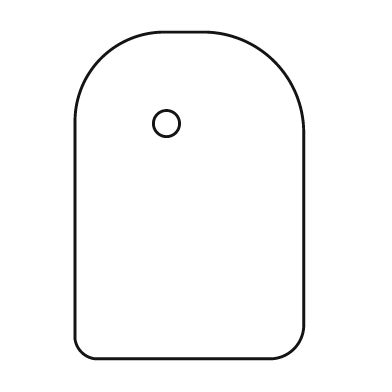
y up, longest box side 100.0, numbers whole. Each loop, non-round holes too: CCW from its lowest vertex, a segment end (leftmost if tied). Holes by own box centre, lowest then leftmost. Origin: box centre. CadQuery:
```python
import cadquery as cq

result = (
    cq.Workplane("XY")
    .moveTo(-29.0, -50.0)
    .lineTo(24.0, -50.0)
    .threePointArc((32.0, -47.0), (35.0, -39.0))
    .lineTo(35.0, 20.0)
    .threePointArc((26.0, 41.0), (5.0, 50.0))
    .lineTo(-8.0, 50.0)
    .threePointArc((-27.0, 42.0), (-35.0, 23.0))
    .lineTo(-35.0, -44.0)
    .threePointArc((-33.0, -48.0), (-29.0, -50.0))
    .close()
    .moveTo(-7.0, 22.0)
    .circle(4.0)
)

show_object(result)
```